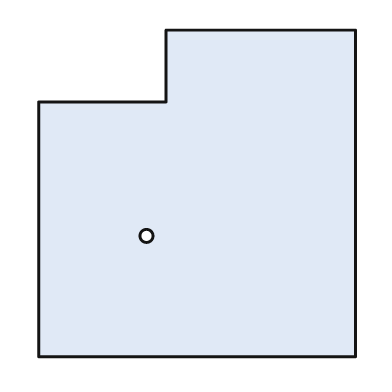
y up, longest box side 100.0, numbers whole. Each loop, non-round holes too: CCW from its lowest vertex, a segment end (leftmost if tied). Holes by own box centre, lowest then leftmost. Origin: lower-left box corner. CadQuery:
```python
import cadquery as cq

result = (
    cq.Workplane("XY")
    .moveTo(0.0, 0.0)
    .lineTo(97.0, 0.0)
    .lineTo(97.0, 100.0)
    .lineTo(39.0, 100.0)
    .lineTo(39.0, 78.0)
    .lineTo(0.0, 78.0)
    .close()
    .moveTo(33.0, 37.0)
    .circle(2.0)
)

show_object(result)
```